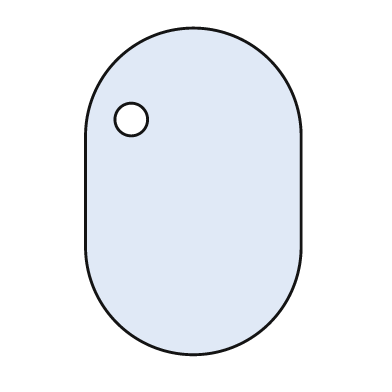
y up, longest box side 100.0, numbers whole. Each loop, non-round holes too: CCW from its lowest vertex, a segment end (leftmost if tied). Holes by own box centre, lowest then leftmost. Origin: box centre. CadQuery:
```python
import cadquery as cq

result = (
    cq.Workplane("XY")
    .moveTo(-33.0, -17.0)
    .threePointArc((0.0, -50.0), (33.0, -17.0))
    .lineTo(33.0, 17.0)
    .threePointArc((0.0, 50.0), (-33.0, 17.0))
    .close()
    .moveTo(-19.0, 22.0)
    .circle(5.0)
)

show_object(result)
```